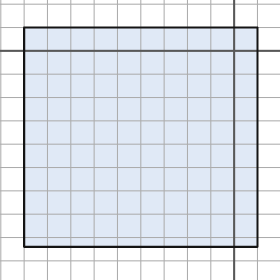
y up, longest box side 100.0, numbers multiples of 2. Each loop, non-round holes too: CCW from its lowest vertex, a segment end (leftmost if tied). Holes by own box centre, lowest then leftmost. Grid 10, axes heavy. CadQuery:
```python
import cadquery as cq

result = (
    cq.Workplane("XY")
    .moveTo(-90.0, -84.0)
    .lineTo(10.0, -84.0)
    .lineTo(10.0, 10.0)
    .lineTo(-90.0, 10.0)
    .close()
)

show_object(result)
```